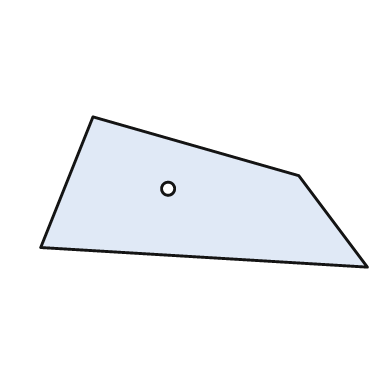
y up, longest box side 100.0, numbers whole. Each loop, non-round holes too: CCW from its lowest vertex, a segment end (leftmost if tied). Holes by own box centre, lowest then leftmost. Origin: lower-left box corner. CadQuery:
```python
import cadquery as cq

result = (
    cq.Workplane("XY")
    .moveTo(100.0, 0.0)
    .lineTo(79.0, 28.0)
    .lineTo(16.0, 46.0)
    .lineTo(0.0, 6.0)
    .close()
    .moveTo(39.0, 24.0)
    .circle(2.0)
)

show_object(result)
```